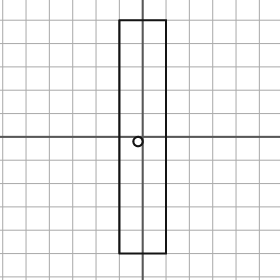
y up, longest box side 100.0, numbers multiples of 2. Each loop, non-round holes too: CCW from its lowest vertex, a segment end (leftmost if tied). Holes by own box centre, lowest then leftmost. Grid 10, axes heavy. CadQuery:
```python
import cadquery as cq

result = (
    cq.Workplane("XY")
    .moveTo(-10.0, -50.0)
    .lineTo(10.0, -50.0)
    .lineTo(10.0, 50.0)
    .lineTo(-10.0, 50.0)
    .close()
    .moveTo(-2.0, -2.0)
    .circle(2.0)
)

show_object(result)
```